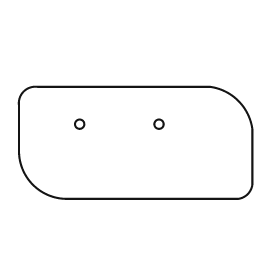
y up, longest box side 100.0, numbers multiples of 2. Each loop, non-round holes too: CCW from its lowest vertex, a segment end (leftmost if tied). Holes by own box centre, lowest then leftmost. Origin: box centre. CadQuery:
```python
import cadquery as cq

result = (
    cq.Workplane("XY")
    .moveTo(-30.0, -24.0)
    .lineTo(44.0, -24.0)
    .threePointArc((48.0, -22.0), (50.0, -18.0))
    .lineTo(50.0, 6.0)
    .threePointArc((44.0, 18.0), (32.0, 24.0))
    .lineTo(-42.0, 24.0)
    .threePointArc((-48.0, 22.0), (-50.0, 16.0))
    .lineTo(-50.0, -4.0)
    .threePointArc((-44.0, -18.0), (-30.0, -24.0))
    .close()
    .moveTo(-24.0, 8.0)
    .circle(2.0)
    .moveTo(10.0, 8.0)
    .circle(2.0)
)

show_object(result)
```